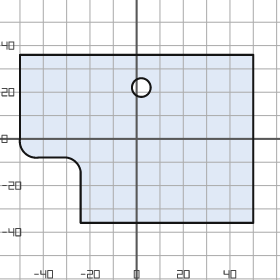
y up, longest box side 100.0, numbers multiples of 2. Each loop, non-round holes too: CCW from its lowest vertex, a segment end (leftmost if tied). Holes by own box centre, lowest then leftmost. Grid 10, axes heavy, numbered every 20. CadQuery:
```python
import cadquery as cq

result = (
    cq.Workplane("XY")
    .moveTo(-24.0, -36.0)
    .lineTo(50.0, -36.0)
    .lineTo(50.0, 36.0)
    .lineTo(-50.0, 36.0)
    .lineTo(-50.0, 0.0)
    .threePointArc((-48.0, -6.0), (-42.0, -8.0))
    .lineTo(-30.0, -8.0)
    .threePointArc((-26.0, -10.0), (-24.0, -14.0))
    .close()
    .moveTo(2.0, 22.0)
    .circle(4.0)
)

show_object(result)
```